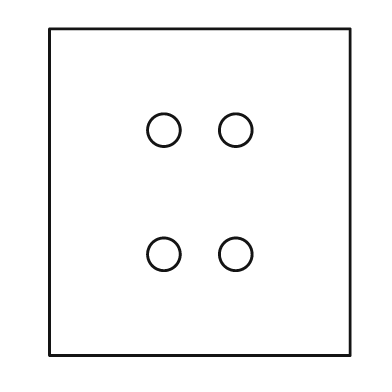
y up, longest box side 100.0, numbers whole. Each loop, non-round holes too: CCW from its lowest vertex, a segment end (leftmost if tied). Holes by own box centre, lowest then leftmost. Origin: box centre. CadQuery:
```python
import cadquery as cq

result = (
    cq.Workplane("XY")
    .moveTo(-46.0, -50.0)
    .lineTo(46.0, -50.0)
    .lineTo(46.0, 50.0)
    .lineTo(-46.0, 50.0)
    .close()
    .moveTo(-11.0, -19.0)
    .circle(5.0)
    .moveTo(11.0, -19.0)
    .circle(5.0)
    .moveTo(-11.0, 19.0)
    .circle(5.0)
    .moveTo(11.0, 19.0)
    .circle(5.0)
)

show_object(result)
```